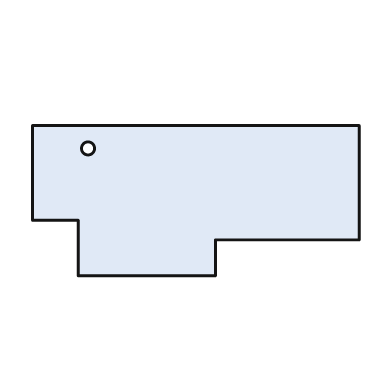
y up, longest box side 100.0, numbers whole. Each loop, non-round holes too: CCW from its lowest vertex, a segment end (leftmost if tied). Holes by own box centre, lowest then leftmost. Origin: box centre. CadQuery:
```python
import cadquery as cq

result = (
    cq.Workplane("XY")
    .moveTo(-36.0, -23.0)
    .lineTo(6.0, -23.0)
    .lineTo(6.0, -12.0)
    .lineTo(50.0, -12.0)
    .lineTo(50.0, 23.0)
    .lineTo(-50.0, 23.0)
    .lineTo(-50.0, -6.0)
    .lineTo(-36.0, -6.0)
    .close()
    .moveTo(-33.0, 16.0)
    .circle(2.0)
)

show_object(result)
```